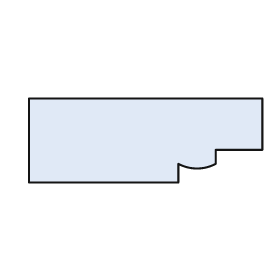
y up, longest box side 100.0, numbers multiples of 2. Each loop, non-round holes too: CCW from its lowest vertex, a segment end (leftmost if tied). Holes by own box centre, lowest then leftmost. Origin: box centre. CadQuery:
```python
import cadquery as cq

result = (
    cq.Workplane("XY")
    .moveTo(-50.0, -18.0)
    .lineTo(14.0, -18.0)
    .lineTo(14.0, -10.0)
    .threePointArc((22.0, -12.0), (30.0, -10.0))
    .lineTo(30.0, -4.0)
    .lineTo(50.0, -4.0)
    .lineTo(50.0, 18.0)
    .lineTo(-50.0, 18.0)
    .close()
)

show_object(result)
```